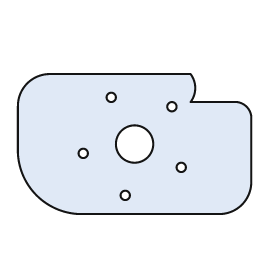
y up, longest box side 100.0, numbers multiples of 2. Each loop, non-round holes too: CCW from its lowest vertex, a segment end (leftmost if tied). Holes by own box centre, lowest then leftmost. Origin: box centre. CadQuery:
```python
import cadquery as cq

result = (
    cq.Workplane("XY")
    .moveTo(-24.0, -30.0)
    .lineTo(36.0, -30.0)
    .threePointArc((46.0, -26.0), (50.0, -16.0))
    .lineTo(50.0, 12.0)
    .threePointArc((48.0, 16.0), (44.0, 18.0))
    .lineTo(24.0, 18.0)
    .threePointArc((26.0, 24.0), (24.0, 30.0))
    .lineTo(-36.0, 30.0)
    .threePointArc((-46.0, 26.0), (-50.0, 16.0))
    .lineTo(-50.0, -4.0)
    .threePointArc((-42.0, -22.0), (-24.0, -30.0))
    .close()
    .moveTo(-4.0, -22.0)
    .circle(2.0)
    .moveTo(20.0, -10.0)
    .circle(2.0)
    .moveTo(-22.0, -4.0)
    .circle(2.0)
    .moveTo(0.0, 0.0)
    .circle(8.0)
    .moveTo(16.0, 16.0)
    .circle(2.0)
    .moveTo(-10.0, 20.0)
    .circle(2.0)
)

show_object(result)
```